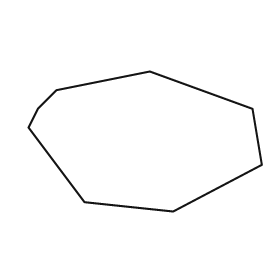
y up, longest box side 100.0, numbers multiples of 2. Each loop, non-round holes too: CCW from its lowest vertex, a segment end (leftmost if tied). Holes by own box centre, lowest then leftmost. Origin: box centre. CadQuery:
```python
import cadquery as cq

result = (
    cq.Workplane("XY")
    .moveTo(12.0, -30.0)
    .lineTo(50.0, -10.0)
    .lineTo(46.0, 14.0)
    .lineTo(2.0, 30.0)
    .lineTo(-38.0, 22.0)
    .lineTo(-46.0, 14.0)
    .lineTo(-50.0, 6.0)
    .lineTo(-26.0, -26.0)
    .close()
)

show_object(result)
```